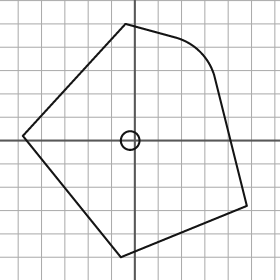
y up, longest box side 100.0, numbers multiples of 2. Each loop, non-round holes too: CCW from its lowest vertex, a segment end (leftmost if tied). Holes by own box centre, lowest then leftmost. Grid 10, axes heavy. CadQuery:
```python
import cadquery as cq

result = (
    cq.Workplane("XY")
    .moveTo(-6.0, -50.0)
    .lineTo(48.0, -28.0)
    .lineTo(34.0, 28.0)
    .threePointArc((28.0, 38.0), (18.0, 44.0))
    .lineTo(-4.0, 50.0)
    .lineTo(-48.0, 2.0)
    .close()
    .moveTo(-2.0, 0.0)
    .circle(4.0)
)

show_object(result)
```